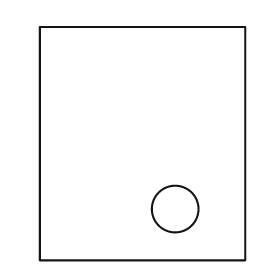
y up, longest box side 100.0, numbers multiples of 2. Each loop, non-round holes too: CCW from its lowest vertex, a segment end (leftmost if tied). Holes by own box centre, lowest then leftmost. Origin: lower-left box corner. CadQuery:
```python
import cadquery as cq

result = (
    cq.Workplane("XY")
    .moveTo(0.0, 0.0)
    .lineTo(88.0, 0.0)
    .lineTo(88.0, 100.0)
    .lineTo(0.0, 100.0)
    .close()
    .moveTo(58.0, 22.0)
    .circle(10.0)
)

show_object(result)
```